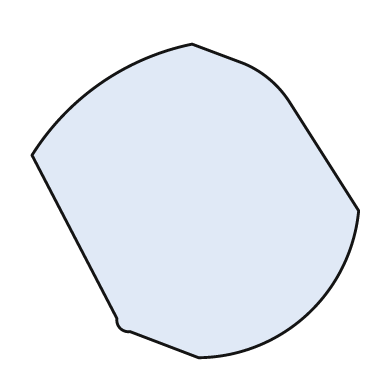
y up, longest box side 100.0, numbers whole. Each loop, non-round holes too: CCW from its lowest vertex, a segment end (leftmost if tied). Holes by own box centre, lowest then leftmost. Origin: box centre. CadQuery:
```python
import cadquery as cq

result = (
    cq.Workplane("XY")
    .moveTo(1.0, -48.0)
    .threePointArc((34.0, -35.0), (50.0, -3.0))
    .lineTo(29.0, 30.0)
    .threePointArc((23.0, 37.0), (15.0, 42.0))
    .lineTo(-1.0, 48.0)
    .threePointArc((-29.0, 36.0), (-50.0, 14.0))
    .lineTo(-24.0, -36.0)
    .threePointArc((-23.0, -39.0), (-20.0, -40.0))
    .close()
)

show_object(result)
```